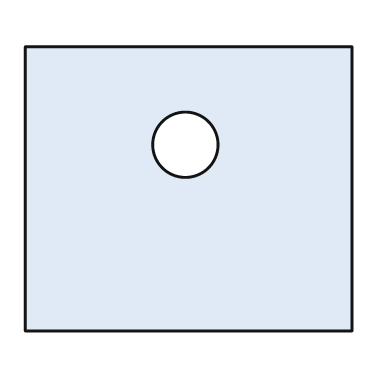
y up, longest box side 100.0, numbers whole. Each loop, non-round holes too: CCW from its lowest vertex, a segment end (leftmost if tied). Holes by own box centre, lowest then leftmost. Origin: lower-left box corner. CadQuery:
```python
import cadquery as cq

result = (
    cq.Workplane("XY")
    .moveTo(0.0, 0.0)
    .lineTo(100.0, 0.0)
    .lineTo(100.0, 87.0)
    .lineTo(0.0, 87.0)
    .close()
    .moveTo(49.0, 57.0)
    .circle(10.0)
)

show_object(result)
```